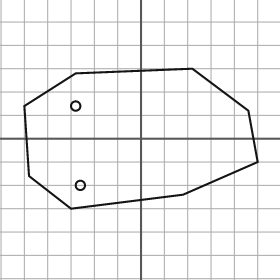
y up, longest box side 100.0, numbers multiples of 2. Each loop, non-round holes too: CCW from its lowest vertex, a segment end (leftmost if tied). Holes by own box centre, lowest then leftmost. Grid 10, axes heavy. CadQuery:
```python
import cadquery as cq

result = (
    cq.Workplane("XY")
    .moveTo(-30.0, -30.0)
    .lineTo(18.0, -24.0)
    .lineTo(50.0, -10.0)
    .lineTo(46.0, 12.0)
    .lineTo(22.0, 30.0)
    .lineTo(-28.0, 28.0)
    .lineTo(-50.0, 14.0)
    .lineTo(-48.0, -16.0)
    .close()
    .moveTo(-26.0, -20.0)
    .circle(2.0)
    .moveTo(-28.0, 14.0)
    .circle(2.0)
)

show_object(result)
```